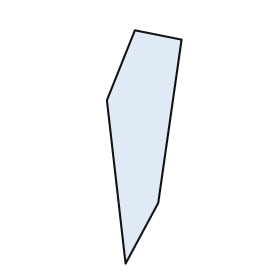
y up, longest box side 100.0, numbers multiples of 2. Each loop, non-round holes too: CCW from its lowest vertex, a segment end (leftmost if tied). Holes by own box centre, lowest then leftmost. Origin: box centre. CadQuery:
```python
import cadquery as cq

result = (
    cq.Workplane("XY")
    .moveTo(-8.0, -50.0)
    .lineTo(6.0, -24.0)
    .lineTo(16.0, 46.0)
    .lineTo(-4.0, 50.0)
    .lineTo(-16.0, 20.0)
    .close()
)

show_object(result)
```